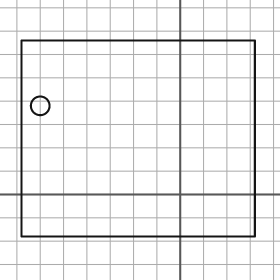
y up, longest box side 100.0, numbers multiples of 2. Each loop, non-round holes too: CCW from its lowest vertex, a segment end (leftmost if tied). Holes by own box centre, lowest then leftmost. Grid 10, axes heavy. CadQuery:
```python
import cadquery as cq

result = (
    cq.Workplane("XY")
    .moveTo(-68.0, -18.0)
    .lineTo(32.0, -18.0)
    .lineTo(32.0, 66.0)
    .lineTo(-68.0, 66.0)
    .close()
    .moveTo(-60.0, 38.0)
    .circle(4.0)
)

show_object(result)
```